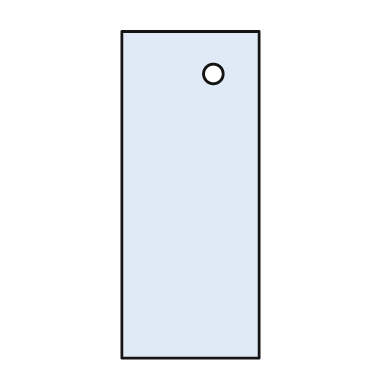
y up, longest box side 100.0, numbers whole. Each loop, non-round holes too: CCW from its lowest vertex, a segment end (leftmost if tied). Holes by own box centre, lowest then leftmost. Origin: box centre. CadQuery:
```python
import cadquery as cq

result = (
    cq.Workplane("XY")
    .moveTo(-21.0, -50.0)
    .lineTo(21.0, -50.0)
    .lineTo(21.0, 50.0)
    .lineTo(-21.0, 50.0)
    .close()
    .moveTo(7.0, 37.0)
    .circle(3.0)
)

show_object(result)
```